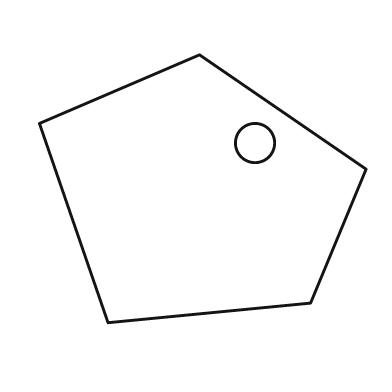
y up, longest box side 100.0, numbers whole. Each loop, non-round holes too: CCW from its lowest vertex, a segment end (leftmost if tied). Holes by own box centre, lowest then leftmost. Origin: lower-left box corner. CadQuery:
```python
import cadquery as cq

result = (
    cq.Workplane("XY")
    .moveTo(21.0, 0.0)
    .lineTo(83.0, 6.0)
    .lineTo(100.0, 47.0)
    .lineTo(49.0, 82.0)
    .lineTo(0.0, 61.0)
    .close()
    .moveTo(66.0, 55.0)
    .circle(6.0)
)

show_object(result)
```